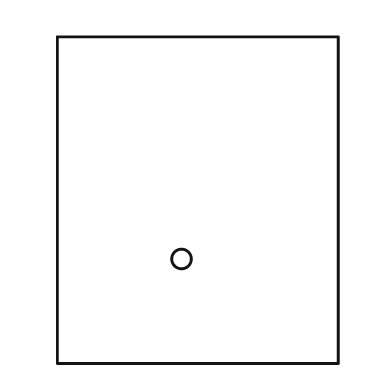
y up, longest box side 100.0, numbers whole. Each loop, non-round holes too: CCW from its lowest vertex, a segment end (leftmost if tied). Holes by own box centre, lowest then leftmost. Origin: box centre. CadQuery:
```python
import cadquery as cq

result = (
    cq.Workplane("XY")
    .moveTo(-43.0, -50.0)
    .lineTo(43.0, -50.0)
    .lineTo(43.0, 50.0)
    .lineTo(-43.0, 50.0)
    .close()
    .moveTo(-5.0, -18.0)
    .circle(3.0)
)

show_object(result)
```